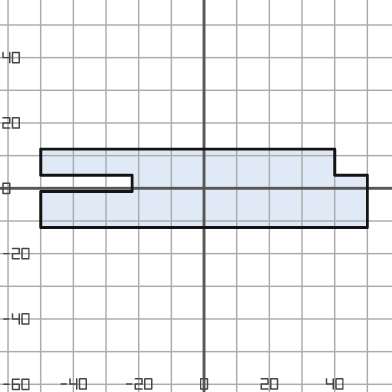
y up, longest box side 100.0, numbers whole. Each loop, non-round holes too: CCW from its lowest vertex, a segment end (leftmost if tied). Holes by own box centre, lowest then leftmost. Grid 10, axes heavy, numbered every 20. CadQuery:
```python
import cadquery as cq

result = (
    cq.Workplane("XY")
    .moveTo(-50.0, -12.0)
    .lineTo(50.0, -12.0)
    .lineTo(50.0, 4.0)
    .lineTo(40.0, 4.0)
    .lineTo(40.0, 12.0)
    .lineTo(-50.0, 12.0)
    .lineTo(-50.0, 4.0)
    .lineTo(-22.0, 4.0)
    .lineTo(-22.0, -1.0)
    .lineTo(-50.0, -1.0)
    .close()
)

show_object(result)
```